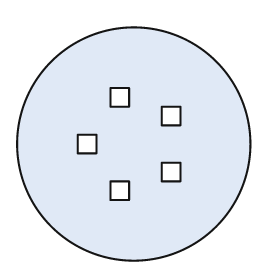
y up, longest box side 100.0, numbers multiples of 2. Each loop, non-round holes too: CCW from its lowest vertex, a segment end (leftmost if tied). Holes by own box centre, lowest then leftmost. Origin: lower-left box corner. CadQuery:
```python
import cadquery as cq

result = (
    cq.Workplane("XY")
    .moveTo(50.0, 50.0)
    .circle(50.0)
    .moveTo(40.0, 26.0)
    .lineTo(48.0, 26.0)
    .lineTo(48.0, 34.0)
    .lineTo(40.0, 34.0)
    .close()
    .moveTo(62.0, 34.0)
    .lineTo(70.0, 34.0)
    .lineTo(70.0, 42.0)
    .lineTo(62.0, 42.0)
    .close()
    .moveTo(26.0, 46.0)
    .lineTo(34.0, 46.0)
    .lineTo(34.0, 54.0)
    .lineTo(26.0, 54.0)
    .close()
    .moveTo(62.0, 58.0)
    .lineTo(70.0, 58.0)
    .lineTo(70.0, 66.0)
    .lineTo(62.0, 66.0)
    .close()
    .moveTo(40.0, 66.0)
    .lineTo(48.0, 66.0)
    .lineTo(48.0, 74.0)
    .lineTo(40.0, 74.0)
    .close()
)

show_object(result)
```